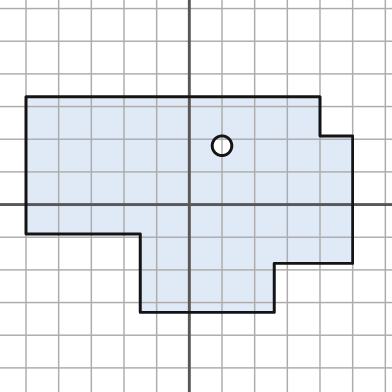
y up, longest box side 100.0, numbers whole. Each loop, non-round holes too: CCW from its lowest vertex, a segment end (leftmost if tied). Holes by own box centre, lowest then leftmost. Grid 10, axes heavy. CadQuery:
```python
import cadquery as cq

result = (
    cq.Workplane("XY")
    .moveTo(-15.0, -33.0)
    .lineTo(26.0, -33.0)
    .lineTo(26.0, -18.0)
    .lineTo(50.0, -18.0)
    .lineTo(50.0, 21.0)
    .lineTo(40.0, 21.0)
    .lineTo(40.0, 33.0)
    .lineTo(-50.0, 33.0)
    .lineTo(-50.0, -9.0)
    .lineTo(-15.0, -9.0)
    .close()
    .moveTo(10.0, 18.0)
    .circle(3.0)
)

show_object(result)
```